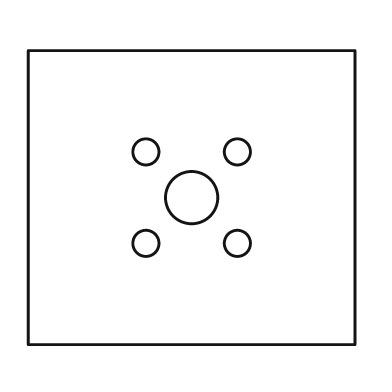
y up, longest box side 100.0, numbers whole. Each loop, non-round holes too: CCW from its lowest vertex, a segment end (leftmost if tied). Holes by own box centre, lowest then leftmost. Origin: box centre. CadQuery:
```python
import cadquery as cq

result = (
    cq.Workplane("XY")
    .moveTo(-50.0, -45.0)
    .lineTo(50.0, -45.0)
    .lineTo(50.0, 45.0)
    .lineTo(-50.0, 45.0)
    .close()
    .moveTo(-14.0, -14.0)
    .circle(4.0)
    .moveTo(14.0, -14.0)
    .circle(4.0)
    .moveTo(0.0, 0.0)
    .circle(8.0)
    .moveTo(-14.0, 14.0)
    .circle(4.0)
    .moveTo(14.0, 14.0)
    .circle(4.0)
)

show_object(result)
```